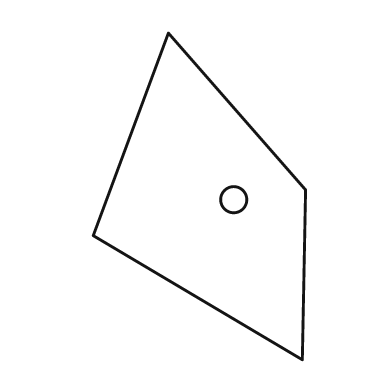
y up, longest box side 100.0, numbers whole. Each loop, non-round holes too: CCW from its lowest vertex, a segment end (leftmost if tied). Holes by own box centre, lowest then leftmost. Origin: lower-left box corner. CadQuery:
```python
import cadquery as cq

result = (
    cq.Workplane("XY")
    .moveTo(64.0, 0.0)
    .lineTo(65.0, 52.0)
    .lineTo(23.0, 100.0)
    .lineTo(0.0, 38.0)
    .close()
    .moveTo(43.0, 49.0)
    .circle(4.0)
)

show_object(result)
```